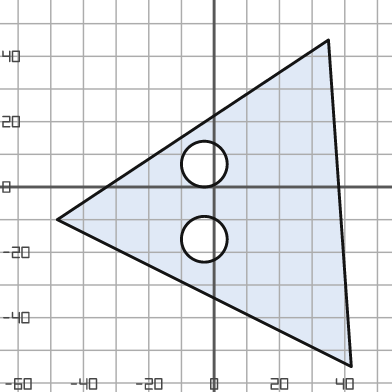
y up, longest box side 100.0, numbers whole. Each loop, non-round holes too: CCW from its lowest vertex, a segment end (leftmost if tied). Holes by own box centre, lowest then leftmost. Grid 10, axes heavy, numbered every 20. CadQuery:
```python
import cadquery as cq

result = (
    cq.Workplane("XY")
    .moveTo(42.0, -55.0)
    .lineTo(35.0, 45.0)
    .lineTo(-48.0, -10.0)
    .close()
    .moveTo(-3.0, -16.0)
    .circle(7.0)
    .moveTo(-3.0, 7.0)
    .circle(7.0)
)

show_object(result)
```